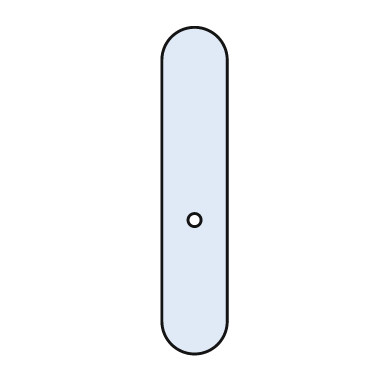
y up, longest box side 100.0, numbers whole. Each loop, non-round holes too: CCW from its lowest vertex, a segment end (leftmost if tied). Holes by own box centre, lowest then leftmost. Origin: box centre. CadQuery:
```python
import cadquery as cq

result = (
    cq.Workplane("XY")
    .moveTo(-10.0, -40.0)
    .threePointArc((0.0, -50.0), (10.0, -40.0))
    .lineTo(10.0, 40.0)
    .threePointArc((0.0, 50.0), (-10.0, 40.0))
    .close()
    .moveTo(0.0, -9.0)
    .circle(2.0)
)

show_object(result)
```